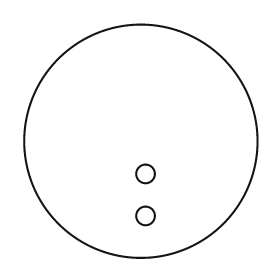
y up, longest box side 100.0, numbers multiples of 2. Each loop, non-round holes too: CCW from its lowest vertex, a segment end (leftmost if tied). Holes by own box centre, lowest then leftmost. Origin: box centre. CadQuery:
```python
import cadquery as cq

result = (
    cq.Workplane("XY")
    .moveTo(0.0, 0.0)
    .circle(50.0)
    .moveTo(2.0, -32.0)
    .circle(4.0)
    .moveTo(2.0, -14.0)
    .circle(4.0)
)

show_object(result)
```